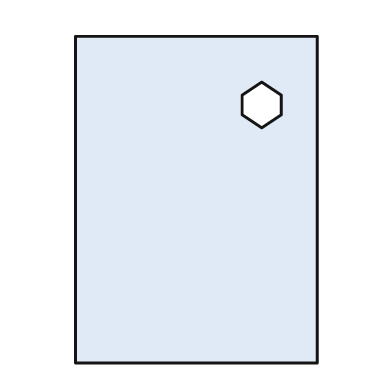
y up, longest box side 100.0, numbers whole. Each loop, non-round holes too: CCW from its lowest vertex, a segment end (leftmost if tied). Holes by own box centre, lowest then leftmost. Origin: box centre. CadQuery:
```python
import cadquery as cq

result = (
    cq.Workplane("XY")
    .moveTo(-37.0, -50.0)
    .lineTo(37.0, -50.0)
    .lineTo(37.0, 50.0)
    .lineTo(-37.0, 50.0)
    .close()
    .moveTo(20.0, 22.0)
    .lineTo(26.0, 26.0)
    .lineTo(26.0, 32.0)
    .lineTo(20.0, 36.0)
    .lineTo(14.0, 32.0)
    .lineTo(14.0, 26.0)
    .close()
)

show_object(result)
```